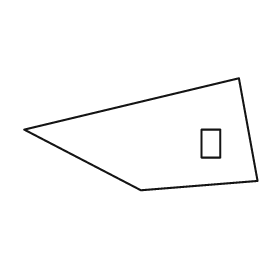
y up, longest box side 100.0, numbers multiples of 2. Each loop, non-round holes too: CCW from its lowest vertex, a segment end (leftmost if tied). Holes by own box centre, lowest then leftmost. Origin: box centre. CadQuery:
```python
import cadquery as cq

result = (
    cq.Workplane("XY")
    .moveTo(0.0, -24.0)
    .lineTo(50.0, -20.0)
    .lineTo(42.0, 24.0)
    .lineTo(-50.0, 2.0)
    .close()
    .moveTo(26.0, -10.0)
    .lineTo(34.0, -10.0)
    .lineTo(34.0, 2.0)
    .lineTo(26.0, 2.0)
    .close()
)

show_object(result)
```